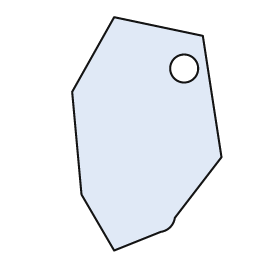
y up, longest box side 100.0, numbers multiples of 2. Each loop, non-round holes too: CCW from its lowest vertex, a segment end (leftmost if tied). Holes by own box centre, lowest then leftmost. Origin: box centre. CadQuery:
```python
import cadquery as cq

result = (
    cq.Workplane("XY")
    .moveTo(-14.0, -50.0)
    .lineTo(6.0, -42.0)
    .threePointArc((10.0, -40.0), (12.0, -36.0))
    .lineTo(32.0, -10.0)
    .lineTo(24.0, 42.0)
    .lineTo(-14.0, 50.0)
    .lineTo(-32.0, 18.0)
    .lineTo(-28.0, -26.0)
    .close()
    .moveTo(16.0, 28.0)
    .circle(6.0)
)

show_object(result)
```